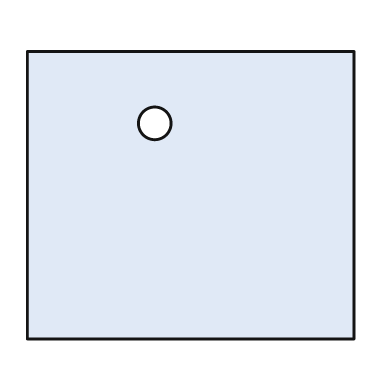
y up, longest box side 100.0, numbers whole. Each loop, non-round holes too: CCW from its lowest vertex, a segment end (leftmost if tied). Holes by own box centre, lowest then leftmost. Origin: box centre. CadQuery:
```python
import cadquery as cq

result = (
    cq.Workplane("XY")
    .moveTo(-50.0, -44.0)
    .lineTo(50.0, -44.0)
    .lineTo(50.0, 44.0)
    .lineTo(-50.0, 44.0)
    .close()
    .moveTo(-11.0, 22.0)
    .circle(5.0)
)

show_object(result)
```